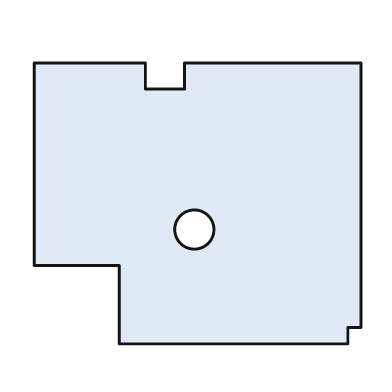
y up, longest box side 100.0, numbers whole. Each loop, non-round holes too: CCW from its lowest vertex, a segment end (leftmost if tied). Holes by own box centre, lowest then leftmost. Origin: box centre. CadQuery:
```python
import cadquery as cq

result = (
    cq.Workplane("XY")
    .moveTo(-24.0, -43.0)
    .lineTo(46.0, -43.0)
    .lineTo(46.0, -38.0)
    .lineTo(50.0, -38.0)
    .lineTo(50.0, 43.0)
    .lineTo(-4.0, 43.0)
    .lineTo(-4.0, 35.0)
    .lineTo(-16.0, 35.0)
    .lineTo(-16.0, 43.0)
    .lineTo(-50.0, 43.0)
    .lineTo(-50.0, -19.0)
    .lineTo(-24.0, -19.0)
    .close()
    .moveTo(-1.0, -8.0)
    .circle(6.0)
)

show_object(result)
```